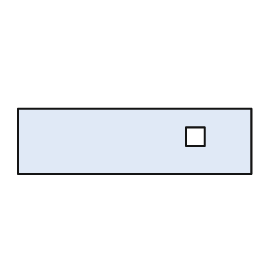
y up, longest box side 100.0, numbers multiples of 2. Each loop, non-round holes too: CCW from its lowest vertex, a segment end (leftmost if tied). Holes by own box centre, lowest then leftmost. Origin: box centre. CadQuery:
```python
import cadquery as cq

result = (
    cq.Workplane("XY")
    .moveTo(-50.0, -14.0)
    .lineTo(50.0, -14.0)
    .lineTo(50.0, 14.0)
    .lineTo(-50.0, 14.0)
    .close()
    .moveTo(22.0, -2.0)
    .lineTo(30.0, -2.0)
    .lineTo(30.0, 6.0)
    .lineTo(22.0, 6.0)
    .close()
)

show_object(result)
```